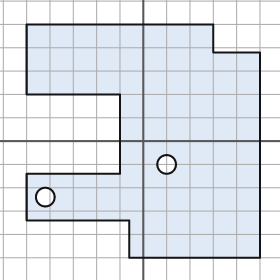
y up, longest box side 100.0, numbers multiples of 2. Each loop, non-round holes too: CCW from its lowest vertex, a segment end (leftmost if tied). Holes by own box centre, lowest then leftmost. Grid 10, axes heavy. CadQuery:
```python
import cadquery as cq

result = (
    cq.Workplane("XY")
    .moveTo(-6.0, -50.0)
    .lineTo(50.0, -50.0)
    .lineTo(50.0, 38.0)
    .lineTo(30.0, 38.0)
    .lineTo(30.0, 50.0)
    .lineTo(-50.0, 50.0)
    .lineTo(-50.0, 20.0)
    .lineTo(-10.0, 20.0)
    .lineTo(-10.0, -14.0)
    .lineTo(-50.0, -14.0)
    .lineTo(-50.0, -34.0)
    .lineTo(-6.0, -34.0)
    .close()
    .moveTo(-42.0, -24.0)
    .circle(4.0)
    .moveTo(10.0, -10.0)
    .circle(4.0)
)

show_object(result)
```